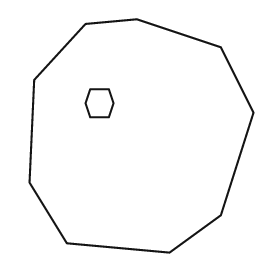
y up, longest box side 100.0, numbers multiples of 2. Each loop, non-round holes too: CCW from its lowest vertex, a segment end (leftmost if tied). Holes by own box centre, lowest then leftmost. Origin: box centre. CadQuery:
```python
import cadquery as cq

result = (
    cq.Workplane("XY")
    .moveTo(12.0, -50.0)
    .lineTo(34.0, -34.0)
    .lineTo(48.0, 10.0)
    .lineTo(34.0, 38.0)
    .lineTo(-2.0, 50.0)
    .lineTo(-24.0, 48.0)
    .lineTo(-46.0, 24.0)
    .lineTo(-48.0, -20.0)
    .lineTo(-32.0, -46.0)
    .close()
    .moveTo(-22.0, 8.0)
    .lineTo(-14.0, 8.0)
    .lineTo(-12.0, 14.0)
    .lineTo(-14.0, 20.0)
    .lineTo(-22.0, 20.0)
    .lineTo(-24.0, 14.0)
    .close()
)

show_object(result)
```